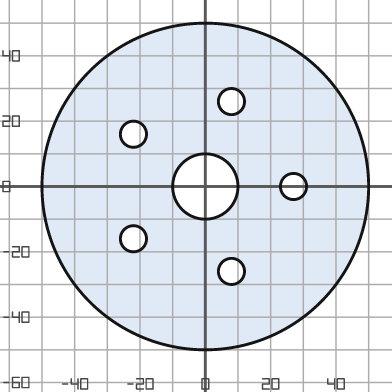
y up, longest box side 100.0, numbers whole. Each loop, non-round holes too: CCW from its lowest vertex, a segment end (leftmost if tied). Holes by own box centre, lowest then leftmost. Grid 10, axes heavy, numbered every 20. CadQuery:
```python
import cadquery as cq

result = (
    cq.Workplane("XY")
    .moveTo(0.0, 0.0)
    .circle(50.0)
    .moveTo(8.0, -26.0)
    .circle(4.0)
    .moveTo(-22.0, -16.0)
    .circle(4.0)
    .moveTo(0.0, 0.0)
    .circle(10.0)
    .moveTo(27.0, 0.0)
    .circle(4.0)
    .moveTo(-22.0, 16.0)
    .circle(4.0)
    .moveTo(8.0, 26.0)
    .circle(4.0)
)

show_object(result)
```